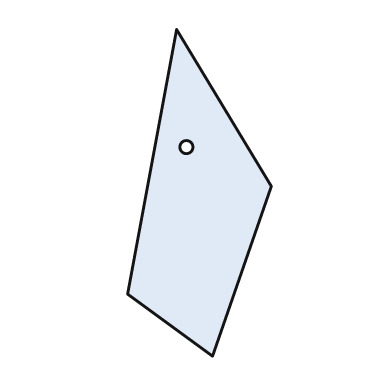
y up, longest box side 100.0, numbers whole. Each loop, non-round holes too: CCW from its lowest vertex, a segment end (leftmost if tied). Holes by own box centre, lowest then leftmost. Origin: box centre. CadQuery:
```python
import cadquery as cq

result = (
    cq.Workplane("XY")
    .moveTo(4.0, -50.0)
    .lineTo(22.0, 2.0)
    .lineTo(-7.0, 50.0)
    .lineTo(-22.0, -31.0)
    .close()
    .moveTo(-4.0, 14.0)
    .circle(2.0)
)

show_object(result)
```